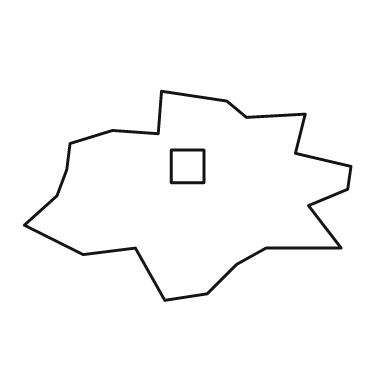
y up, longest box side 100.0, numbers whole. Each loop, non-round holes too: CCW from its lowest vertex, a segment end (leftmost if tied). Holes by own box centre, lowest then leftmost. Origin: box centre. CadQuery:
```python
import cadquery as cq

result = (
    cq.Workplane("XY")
    .moveTo(-7.0, -32.0)
    .lineTo(6.0, -30.0)
    .lineTo(15.0, -21.0)
    .lineTo(24.0, -16.0)
    .lineTo(47.0, -16.0)
    .lineTo(37.0, -3.0)
    .lineTo(49.0, 2.0)
    .lineTo(50.0, 9.0)
    .lineTo(33.0, 13.0)
    .lineTo(36.0, 25.0)
    .lineTo(18.0, 24.0)
    .lineTo(12.0, 29.0)
    .lineTo(-8.0, 32.0)
    .lineTo(-9.0, 19.0)
    .lineTo(-23.0, 20.0)
    .lineTo(-36.0, 16.0)
    .lineTo(-37.0, 8.0)
    .lineTo(-40.0, 0.0)
    .lineTo(-50.0, -9.0)
    .lineTo(-32.0, -18.0)
    .lineTo(-16.0, -16.0)
    .close()
    .moveTo(-5.0, 4.0)
    .lineTo(5.0, 4.0)
    .lineTo(5.0, 14.0)
    .lineTo(-5.0, 14.0)
    .close()
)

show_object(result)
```